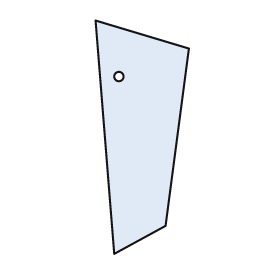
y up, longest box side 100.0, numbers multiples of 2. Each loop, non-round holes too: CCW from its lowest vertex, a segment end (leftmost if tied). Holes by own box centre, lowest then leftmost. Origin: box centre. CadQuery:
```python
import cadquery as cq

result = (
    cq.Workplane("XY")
    .moveTo(-12.0, -50.0)
    .lineTo(10.0, -38.0)
    .lineTo(20.0, 38.0)
    .lineTo(-20.0, 50.0)
    .close()
    .moveTo(-10.0, 26.0)
    .circle(2.0)
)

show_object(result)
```